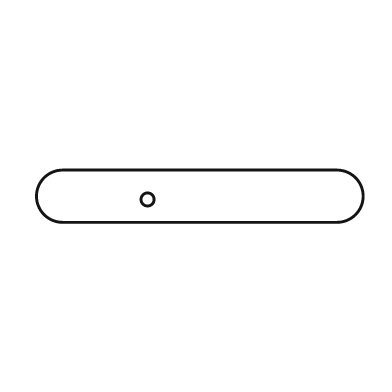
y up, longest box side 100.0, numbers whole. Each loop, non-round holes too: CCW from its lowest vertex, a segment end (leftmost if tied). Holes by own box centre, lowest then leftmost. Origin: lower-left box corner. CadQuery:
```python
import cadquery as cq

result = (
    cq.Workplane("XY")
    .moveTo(8.0, 0.0)
    .lineTo(92.0, 0.0)
    .threePointArc((100.0, 8.0), (92.0, 16.0))
    .lineTo(8.0, 16.0)
    .threePointArc((0.0, 8.0), (8.0, 0.0))
    .close()
    .moveTo(34.0, 7.0)
    .circle(2.0)
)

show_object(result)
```